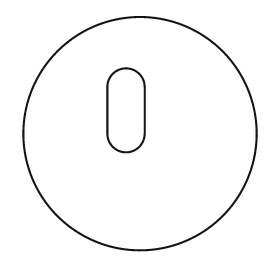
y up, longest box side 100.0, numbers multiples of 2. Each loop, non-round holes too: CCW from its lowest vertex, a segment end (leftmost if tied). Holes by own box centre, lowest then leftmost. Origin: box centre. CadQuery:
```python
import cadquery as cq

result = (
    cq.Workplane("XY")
    .moveTo(0.0, 0.0)
    .circle(50.0)
    .moveTo(-14.0, 0.0)
    .threePointArc((-6.0, -8.0), (2.0, 0.0))
    .lineTo(2.0, 20.0)
    .threePointArc((-6.0, 28.0), (-14.0, 20.0))
    .close()
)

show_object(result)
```